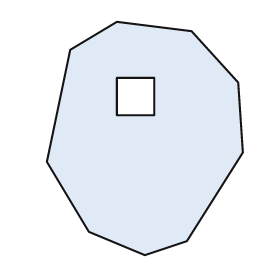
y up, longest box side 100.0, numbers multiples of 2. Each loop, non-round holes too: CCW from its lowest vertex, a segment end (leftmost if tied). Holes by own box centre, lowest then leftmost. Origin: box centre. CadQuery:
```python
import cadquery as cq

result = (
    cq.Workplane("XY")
    .moveTo(0.0, -50.0)
    .lineTo(18.0, -44.0)
    .lineTo(42.0, -6.0)
    .lineTo(40.0, 24.0)
    .lineTo(20.0, 46.0)
    .lineTo(-12.0, 50.0)
    .lineTo(-32.0, 38.0)
    .lineTo(-42.0, -10.0)
    .lineTo(-24.0, -40.0)
    .close()
    .moveTo(-12.0, 10.0)
    .lineTo(4.0, 10.0)
    .lineTo(4.0, 26.0)
    .lineTo(-12.0, 26.0)
    .close()
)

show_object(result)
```